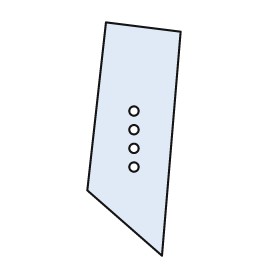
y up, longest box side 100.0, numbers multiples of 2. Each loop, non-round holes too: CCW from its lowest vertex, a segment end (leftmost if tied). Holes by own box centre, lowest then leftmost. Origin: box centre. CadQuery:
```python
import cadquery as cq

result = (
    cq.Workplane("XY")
    .moveTo(12.0, -50.0)
    .lineTo(20.0, 46.0)
    .lineTo(-12.0, 50.0)
    .lineTo(-20.0, -22.0)
    .close()
    .moveTo(0.0, -12.0)
    .circle(2.0)
    .moveTo(0.0, -4.0)
    .circle(2.0)
    .moveTo(0.0, 4.0)
    .circle(2.0)
    .moveTo(0.0, 12.0)
    .circle(2.0)
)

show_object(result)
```